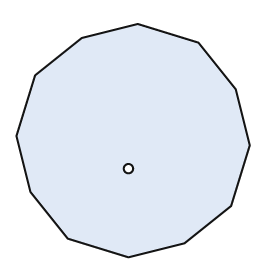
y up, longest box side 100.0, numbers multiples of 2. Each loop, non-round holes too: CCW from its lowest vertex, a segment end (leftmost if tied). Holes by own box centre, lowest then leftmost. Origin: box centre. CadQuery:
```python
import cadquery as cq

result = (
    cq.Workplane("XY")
    .moveTo(-2.0, -50.0)
    .lineTo(22.0, -44.0)
    .lineTo(42.0, -28.0)
    .lineTo(50.0, -2.0)
    .lineTo(44.0, 22.0)
    .lineTo(28.0, 42.0)
    .lineTo(2.0, 50.0)
    .lineTo(-22.0, 44.0)
    .lineTo(-42.0, 28.0)
    .lineTo(-50.0, 2.0)
    .lineTo(-44.0, -22.0)
    .lineTo(-28.0, -42.0)
    .close()
    .moveTo(-2.0, -12.0)
    .circle(2.0)
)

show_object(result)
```